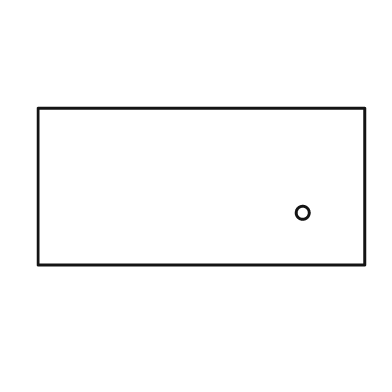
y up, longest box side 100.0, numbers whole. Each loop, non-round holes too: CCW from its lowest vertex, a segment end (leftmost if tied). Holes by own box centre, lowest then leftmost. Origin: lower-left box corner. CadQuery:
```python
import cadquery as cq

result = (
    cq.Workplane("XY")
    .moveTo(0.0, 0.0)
    .lineTo(100.0, 0.0)
    .lineTo(100.0, 48.0)
    .lineTo(0.0, 48.0)
    .close()
    .moveTo(81.0, 16.0)
    .circle(2.0)
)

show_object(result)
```